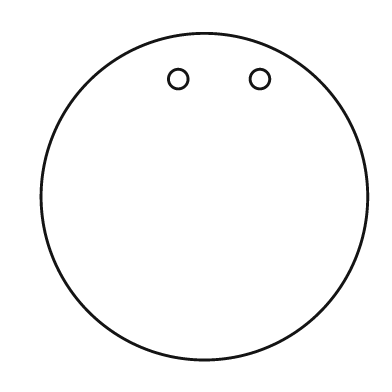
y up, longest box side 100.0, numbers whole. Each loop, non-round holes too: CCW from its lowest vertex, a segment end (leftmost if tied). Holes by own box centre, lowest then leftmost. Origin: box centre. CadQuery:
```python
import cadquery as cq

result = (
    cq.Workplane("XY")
    .moveTo(0.0, 0.0)
    .circle(50.0)
    .moveTo(-8.0, 36.0)
    .circle(3.0)
    .moveTo(17.0, 36.0)
    .circle(3.0)
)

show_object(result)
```